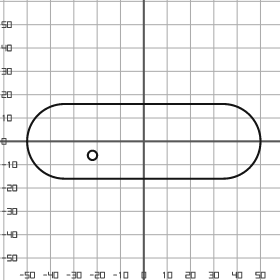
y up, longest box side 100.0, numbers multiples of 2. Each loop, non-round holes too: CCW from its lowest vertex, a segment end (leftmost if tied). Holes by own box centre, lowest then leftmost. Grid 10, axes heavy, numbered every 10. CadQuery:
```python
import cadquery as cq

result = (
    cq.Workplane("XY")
    .moveTo(-34.0, -16.0)
    .lineTo(34.0, -16.0)
    .threePointArc((50.0, 0.0), (34.0, 16.0))
    .lineTo(-34.0, 16.0)
    .threePointArc((-50.0, 0.0), (-34.0, -16.0))
    .close()
    .moveTo(-22.0, -6.0)
    .circle(2.0)
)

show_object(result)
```